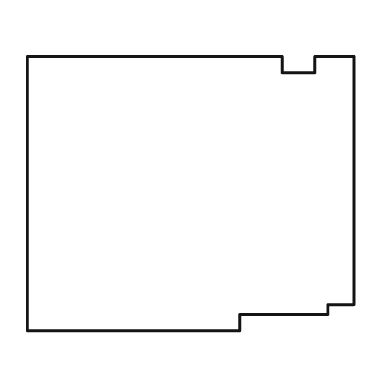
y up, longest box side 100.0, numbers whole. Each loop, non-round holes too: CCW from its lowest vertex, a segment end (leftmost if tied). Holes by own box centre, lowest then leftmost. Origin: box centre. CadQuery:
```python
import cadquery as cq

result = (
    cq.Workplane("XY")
    .moveTo(-50.0, -42.0)
    .lineTo(15.0, -42.0)
    .lineTo(15.0, -37.0)
    .lineTo(42.0, -37.0)
    .lineTo(42.0, -34.0)
    .lineTo(50.0, -34.0)
    .lineTo(50.0, 42.0)
    .lineTo(38.0, 42.0)
    .lineTo(38.0, 37.0)
    .lineTo(28.0, 37.0)
    .lineTo(28.0, 42.0)
    .lineTo(-50.0, 42.0)
    .close()
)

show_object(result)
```